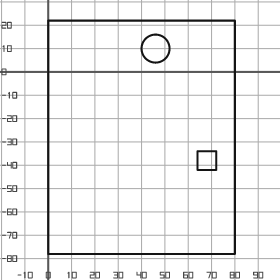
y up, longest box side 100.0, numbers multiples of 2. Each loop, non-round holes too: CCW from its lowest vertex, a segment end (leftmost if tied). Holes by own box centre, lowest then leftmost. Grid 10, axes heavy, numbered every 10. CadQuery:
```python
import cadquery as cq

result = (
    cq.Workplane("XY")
    .moveTo(0.0, -78.0)
    .lineTo(80.0, -78.0)
    .lineTo(80.0, 22.0)
    .lineTo(0.0, 22.0)
    .close()
    .moveTo(64.0, -42.0)
    .lineTo(72.0, -42.0)
    .lineTo(72.0, -34.0)
    .lineTo(64.0, -34.0)
    .close()
    .moveTo(46.0, 10.0)
    .circle(6.0)
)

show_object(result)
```